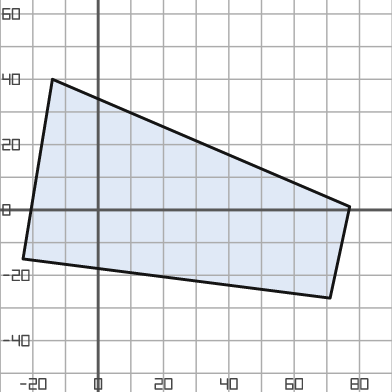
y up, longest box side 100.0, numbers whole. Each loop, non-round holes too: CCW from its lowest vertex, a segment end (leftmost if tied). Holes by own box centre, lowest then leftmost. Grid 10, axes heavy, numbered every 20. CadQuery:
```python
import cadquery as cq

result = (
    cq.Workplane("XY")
    .moveTo(71.0, -27.0)
    .lineTo(77.0, 1.0)
    .lineTo(-14.0, 40.0)
    .lineTo(-23.0, -15.0)
    .close()
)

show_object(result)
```